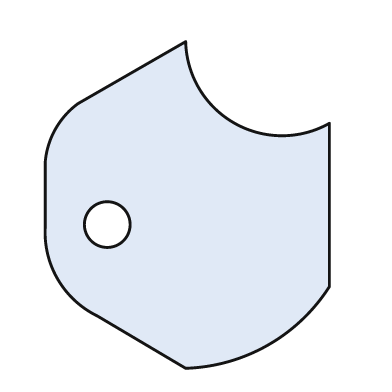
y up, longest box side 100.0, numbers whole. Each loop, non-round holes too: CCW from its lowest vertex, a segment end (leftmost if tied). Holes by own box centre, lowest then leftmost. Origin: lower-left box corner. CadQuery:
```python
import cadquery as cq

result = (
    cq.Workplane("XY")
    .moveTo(43.0, 0.0)
    .threePointArc((68.0, 7.0), (87.0, 25.0))
    .lineTo(87.0, 75.0)
    .threePointArc((58.0, 75.0), (43.0, 100.0))
    .lineTo(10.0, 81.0)
    .threePointArc((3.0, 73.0), (0.0, 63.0))
    .lineTo(0.0, 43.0)
    .threePointArc((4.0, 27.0), (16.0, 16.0))
    .close()
    .moveTo(19.0, 44.0)
    .circle(7.0)
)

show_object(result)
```